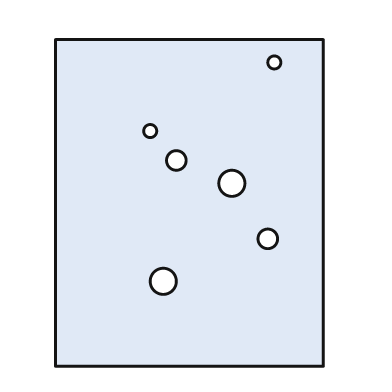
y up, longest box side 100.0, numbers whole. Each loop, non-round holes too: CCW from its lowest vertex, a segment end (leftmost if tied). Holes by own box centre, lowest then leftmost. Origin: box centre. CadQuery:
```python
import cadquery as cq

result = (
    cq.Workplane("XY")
    .moveTo(-41.0, -50.0)
    .lineTo(41.0, -50.0)
    .lineTo(41.0, 50.0)
    .lineTo(-41.0, 50.0)
    .close()
    .moveTo(-8.0, -24.0)
    .circle(4.0)
    .moveTo(24.0, -11.0)
    .circle(3.0)
    .moveTo(13.0, 6.0)
    .circle(4.0)
    .moveTo(-4.0, 13.0)
    .circle(3.0)
    .moveTo(-12.0, 22.0)
    .circle(2.0)
    .moveTo(26.0, 43.0)
    .circle(2.0)
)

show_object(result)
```